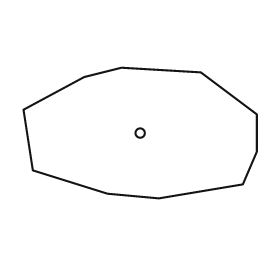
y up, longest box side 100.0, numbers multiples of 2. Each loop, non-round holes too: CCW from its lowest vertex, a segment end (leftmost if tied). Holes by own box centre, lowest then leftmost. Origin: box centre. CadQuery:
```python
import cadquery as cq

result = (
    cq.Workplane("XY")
    .moveTo(8.0, -28.0)
    .lineTo(44.0, -22.0)
    .lineTo(50.0, -8.0)
    .lineTo(50.0, 8.0)
    .lineTo(26.0, 26.0)
    .lineTo(-8.0, 28.0)
    .lineTo(-24.0, 24.0)
    .lineTo(-50.0, 10.0)
    .lineTo(-46.0, -16.0)
    .lineTo(-14.0, -26.0)
    .close()
    .moveTo(0.0, 0.0)
    .circle(2.0)
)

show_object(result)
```